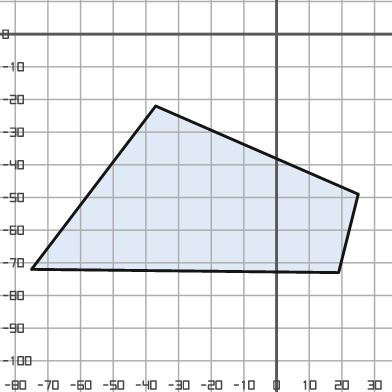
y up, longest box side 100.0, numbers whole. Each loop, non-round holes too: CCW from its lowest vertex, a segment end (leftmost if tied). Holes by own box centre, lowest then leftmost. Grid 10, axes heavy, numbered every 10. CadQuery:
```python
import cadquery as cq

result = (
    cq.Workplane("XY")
    .moveTo(19.0, -73.0)
    .lineTo(25.0, -49.0)
    .lineTo(-37.0, -22.0)
    .lineTo(-75.0, -72.0)
    .close()
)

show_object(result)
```